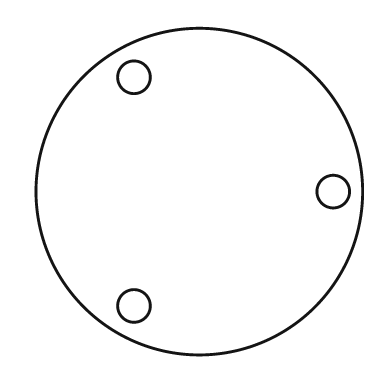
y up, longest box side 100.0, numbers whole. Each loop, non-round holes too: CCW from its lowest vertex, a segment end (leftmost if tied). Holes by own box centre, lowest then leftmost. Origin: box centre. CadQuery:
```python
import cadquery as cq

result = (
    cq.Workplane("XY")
    .moveTo(0.0, 0.0)
    .circle(50.0)
    .moveTo(-20.0, -35.0)
    .circle(5.0)
    .moveTo(41.0, 0.0)
    .circle(5.0)
    .moveTo(-20.0, 35.0)
    .circle(5.0)
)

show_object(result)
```